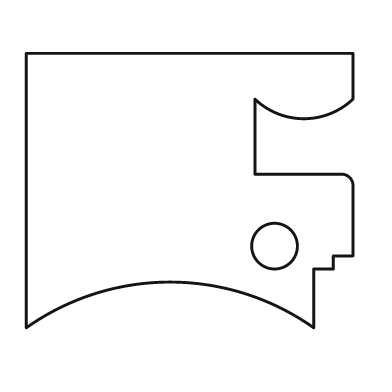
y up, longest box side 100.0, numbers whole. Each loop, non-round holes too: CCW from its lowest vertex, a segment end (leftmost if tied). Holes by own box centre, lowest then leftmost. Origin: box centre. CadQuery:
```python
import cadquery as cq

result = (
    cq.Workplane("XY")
    .moveTo(-50.0, -42.0)
    .threePointArc((-6.0, -28.0), (38.0, -42.0))
    .lineTo(38.0, -24.0)
    .lineTo(44.0, -24.0)
    .lineTo(44.0, -20.0)
    .lineTo(50.0, -20.0)
    .lineTo(50.0, 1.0)
    .threePointArc((49.0, 4.0), (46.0, 5.0))
    .lineTo(20.0, 5.0)
    .lineTo(20.0, 28.0)
    .threePointArc((35.0, 22.0), (50.0, 28.0))
    .lineTo(50.0, 42.0)
    .lineTo(-50.0, 42.0)
    .close()
    .moveTo(26.0, -17.0)
    .circle(7.0)
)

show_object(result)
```